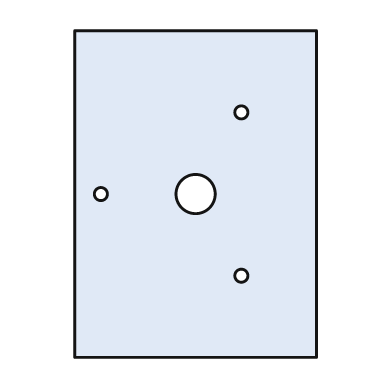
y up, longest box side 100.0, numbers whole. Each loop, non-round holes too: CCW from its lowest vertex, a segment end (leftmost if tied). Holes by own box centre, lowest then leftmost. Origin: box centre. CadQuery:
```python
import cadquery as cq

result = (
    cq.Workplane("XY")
    .moveTo(-37.0, -50.0)
    .lineTo(37.0, -50.0)
    .lineTo(37.0, 50.0)
    .lineTo(-37.0, 50.0)
    .close()
    .moveTo(14.0, -25.0)
    .circle(2.0)
    .moveTo(-29.0, 0.0)
    .circle(2.0)
    .moveTo(0.0, 0.0)
    .circle(6.0)
    .moveTo(14.0, 25.0)
    .circle(2.0)
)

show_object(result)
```